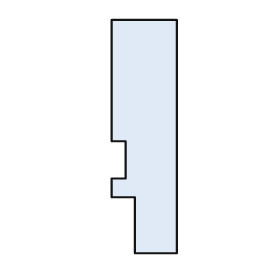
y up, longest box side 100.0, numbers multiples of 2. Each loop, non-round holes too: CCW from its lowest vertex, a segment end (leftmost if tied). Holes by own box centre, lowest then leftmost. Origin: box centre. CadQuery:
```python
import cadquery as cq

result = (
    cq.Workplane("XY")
    .moveTo(-4.0, -50.0)
    .lineTo(14.0, -50.0)
    .lineTo(14.0, 50.0)
    .lineTo(-14.0, 50.0)
    .lineTo(-14.0, -2.0)
    .lineTo(-8.0, -2.0)
    .lineTo(-8.0, -18.0)
    .lineTo(-14.0, -18.0)
    .lineTo(-14.0, -26.0)
    .lineTo(-4.0, -26.0)
    .close()
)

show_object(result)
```